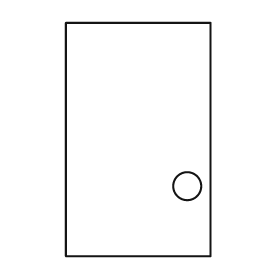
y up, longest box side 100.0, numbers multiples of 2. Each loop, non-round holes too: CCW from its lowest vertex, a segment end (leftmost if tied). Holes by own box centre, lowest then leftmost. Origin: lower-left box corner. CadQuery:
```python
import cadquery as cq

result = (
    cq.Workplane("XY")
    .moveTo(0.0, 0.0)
    .lineTo(62.0, 0.0)
    .lineTo(62.0, 100.0)
    .lineTo(0.0, 100.0)
    .close()
    .moveTo(52.0, 30.0)
    .circle(6.0)
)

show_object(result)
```